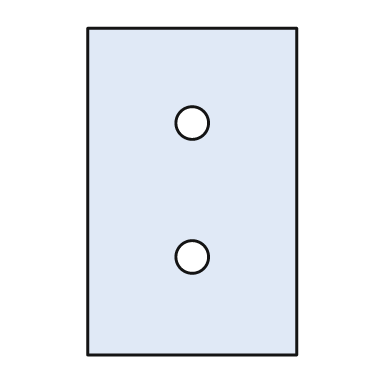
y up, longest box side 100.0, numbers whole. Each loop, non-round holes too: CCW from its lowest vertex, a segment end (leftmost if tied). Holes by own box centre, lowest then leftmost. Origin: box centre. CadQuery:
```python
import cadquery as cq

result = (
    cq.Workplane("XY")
    .moveTo(-32.0, -50.0)
    .lineTo(32.0, -50.0)
    .lineTo(32.0, 50.0)
    .lineTo(-32.0, 50.0)
    .close()
    .moveTo(0.0, -20.0)
    .circle(5.0)
    .moveTo(0.0, 21.0)
    .circle(5.0)
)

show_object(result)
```